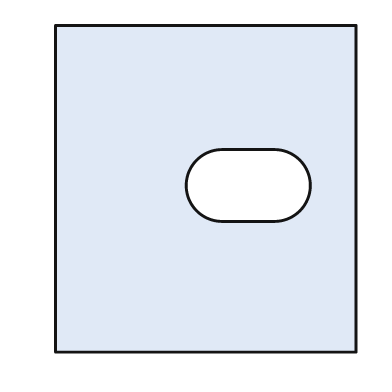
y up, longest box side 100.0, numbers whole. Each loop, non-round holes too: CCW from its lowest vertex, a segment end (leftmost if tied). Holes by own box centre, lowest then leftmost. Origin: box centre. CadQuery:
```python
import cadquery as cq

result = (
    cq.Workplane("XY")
    .moveTo(-46.0, -50.0)
    .lineTo(46.0, -50.0)
    .lineTo(46.0, 50.0)
    .lineTo(-46.0, 50.0)
    .close()
    .moveTo(5.0, -10.0)
    .lineTo(21.0, -10.0)
    .threePointArc((32.0, 1.0), (21.0, 12.0))
    .lineTo(5.0, 12.0)
    .threePointArc((-6.0, 1.0), (5.0, -10.0))
    .close()
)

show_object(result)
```